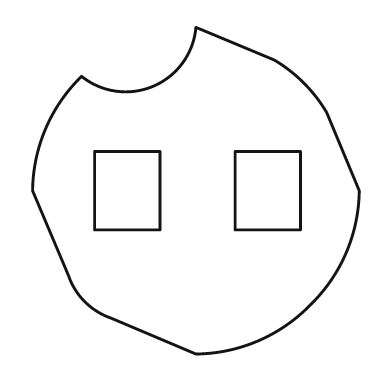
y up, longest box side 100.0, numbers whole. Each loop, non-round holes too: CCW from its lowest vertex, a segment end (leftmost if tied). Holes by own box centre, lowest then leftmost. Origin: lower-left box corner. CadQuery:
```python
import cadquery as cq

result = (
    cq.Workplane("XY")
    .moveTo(50.0, 0.0)
    .threePointArc((69.0, 4.0), (85.0, 15.0))
    .threePointArc((96.0, 31.0), (100.0, 50.0))
    .lineTo(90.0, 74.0)
    .threePointArc((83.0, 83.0), (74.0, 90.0))
    .lineTo(50.0, 100.0)
    .threePointArc((37.0, 82.0), (15.0, 85.0))
    .threePointArc((4.0, 69.0), (0.0, 50.0))
    .lineTo(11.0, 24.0)
    .threePointArc((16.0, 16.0), (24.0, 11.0))
    .close()
    .moveTo(19.0, 38.0)
    .lineTo(39.0, 38.0)
    .lineTo(39.0, 62.0)
    .lineTo(19.0, 62.0)
    .close()
    .moveTo(62.0, 38.0)
    .lineTo(82.0, 38.0)
    .lineTo(82.0, 62.0)
    .lineTo(62.0, 62.0)
    .close()
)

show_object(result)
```